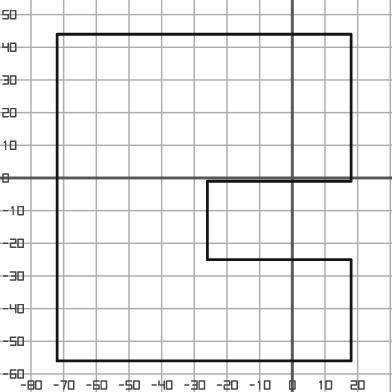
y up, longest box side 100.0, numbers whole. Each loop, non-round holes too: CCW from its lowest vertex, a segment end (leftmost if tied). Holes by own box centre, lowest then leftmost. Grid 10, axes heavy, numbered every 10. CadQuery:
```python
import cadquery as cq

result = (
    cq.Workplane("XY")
    .moveTo(-72.0, -56.0)
    .lineTo(18.0, -56.0)
    .lineTo(18.0, -25.0)
    .lineTo(-26.0, -25.0)
    .lineTo(-26.0, -1.0)
    .lineTo(18.0, -1.0)
    .lineTo(18.0, 44.0)
    .lineTo(-72.0, 44.0)
    .close()
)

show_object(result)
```